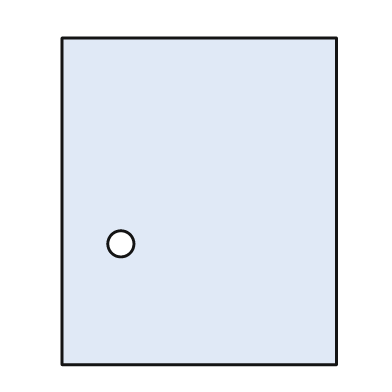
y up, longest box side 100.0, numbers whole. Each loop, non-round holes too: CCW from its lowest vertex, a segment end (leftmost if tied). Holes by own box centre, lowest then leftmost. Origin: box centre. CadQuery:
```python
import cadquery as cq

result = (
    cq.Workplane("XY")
    .moveTo(-42.0, -50.0)
    .lineTo(42.0, -50.0)
    .lineTo(42.0, 50.0)
    .lineTo(-42.0, 50.0)
    .close()
    .moveTo(-24.0, -13.0)
    .circle(4.0)
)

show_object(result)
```